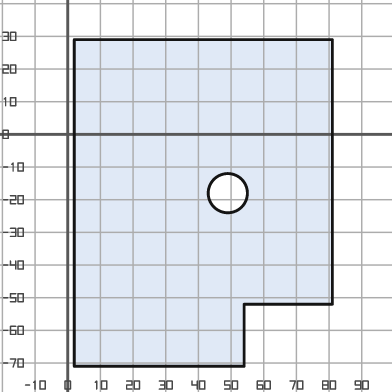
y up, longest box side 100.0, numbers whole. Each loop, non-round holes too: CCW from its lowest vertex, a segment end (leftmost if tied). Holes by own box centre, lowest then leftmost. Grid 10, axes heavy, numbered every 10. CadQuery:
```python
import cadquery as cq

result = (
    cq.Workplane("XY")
    .moveTo(2.0, -71.0)
    .lineTo(54.0, -71.0)
    .lineTo(54.0, -52.0)
    .lineTo(81.0, -52.0)
    .lineTo(81.0, 29.0)
    .lineTo(2.0, 29.0)
    .close()
    .moveTo(49.0, -18.0)
    .circle(6.0)
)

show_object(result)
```